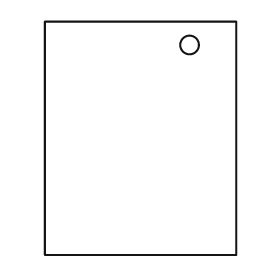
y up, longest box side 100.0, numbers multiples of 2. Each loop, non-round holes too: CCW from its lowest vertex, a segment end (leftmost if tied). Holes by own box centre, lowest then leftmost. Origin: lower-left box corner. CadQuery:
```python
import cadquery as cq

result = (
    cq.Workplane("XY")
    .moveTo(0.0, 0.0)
    .lineTo(82.0, 0.0)
    .lineTo(82.0, 100.0)
    .lineTo(0.0, 100.0)
    .close()
    .moveTo(62.0, 90.0)
    .circle(4.0)
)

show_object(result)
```